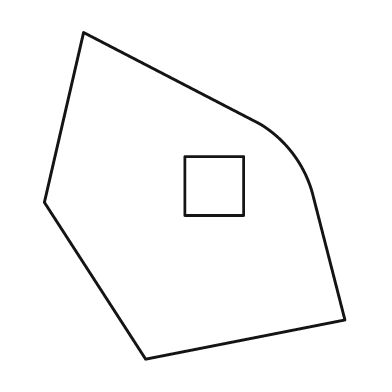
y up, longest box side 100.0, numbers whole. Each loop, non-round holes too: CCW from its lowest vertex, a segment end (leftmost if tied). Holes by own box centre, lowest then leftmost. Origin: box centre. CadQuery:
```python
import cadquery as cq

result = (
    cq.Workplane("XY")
    .moveTo(-15.0, -50.0)
    .lineTo(46.0, -38.0)
    .lineTo(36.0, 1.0)
    .threePointArc((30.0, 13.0), (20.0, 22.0))
    .lineTo(-34.0, 50.0)
    .lineTo(-46.0, -2.0)
    .close()
    .moveTo(-3.0, -6.0)
    .lineTo(15.0, -6.0)
    .lineTo(15.0, 12.0)
    .lineTo(-3.0, 12.0)
    .close()
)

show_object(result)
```